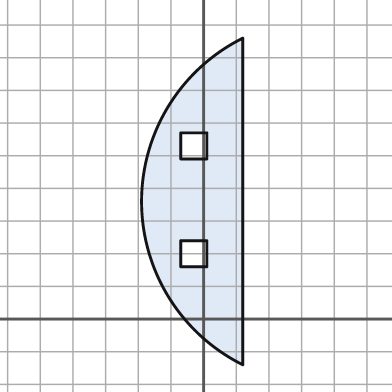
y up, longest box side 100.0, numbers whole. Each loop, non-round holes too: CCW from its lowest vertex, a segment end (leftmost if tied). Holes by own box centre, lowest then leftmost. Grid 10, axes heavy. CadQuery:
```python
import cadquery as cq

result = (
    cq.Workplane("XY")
    .moveTo(12.0, -14.0)
    .lineTo(12.0, 86.0)
    .threePointArc((-19.0, 36.0), (12.0, -14.0))
    .close()
    .moveTo(-7.0, 16.0)
    .lineTo(1.0, 16.0)
    .lineTo(1.0, 24.0)
    .lineTo(-7.0, 24.0)
    .close()
    .moveTo(-7.0, 49.0)
    .lineTo(1.0, 49.0)
    .lineTo(1.0, 57.0)
    .lineTo(-7.0, 57.0)
    .close()
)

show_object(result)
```